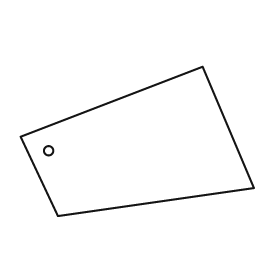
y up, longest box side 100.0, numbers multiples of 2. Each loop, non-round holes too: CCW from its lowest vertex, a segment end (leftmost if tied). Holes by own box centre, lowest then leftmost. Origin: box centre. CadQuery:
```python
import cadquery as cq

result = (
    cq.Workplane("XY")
    .moveTo(-34.0, -32.0)
    .lineTo(50.0, -20.0)
    .lineTo(28.0, 32.0)
    .lineTo(-50.0, 2.0)
    .close()
    .moveTo(-38.0, -4.0)
    .circle(2.0)
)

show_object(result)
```